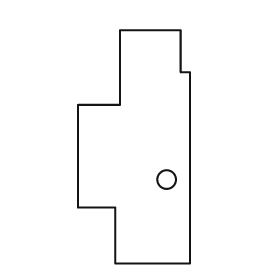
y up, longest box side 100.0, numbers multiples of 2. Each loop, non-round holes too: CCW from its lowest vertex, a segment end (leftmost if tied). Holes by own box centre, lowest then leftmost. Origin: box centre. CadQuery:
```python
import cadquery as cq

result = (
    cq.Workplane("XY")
    .moveTo(-8.0, -50.0)
    .lineTo(24.0, -50.0)
    .lineTo(24.0, 32.0)
    .lineTo(20.0, 32.0)
    .lineTo(20.0, 50.0)
    .lineTo(-6.0, 50.0)
    .lineTo(-6.0, 18.0)
    .lineTo(-24.0, 18.0)
    .lineTo(-24.0, -26.0)
    .lineTo(-8.0, -26.0)
    .close()
    .moveTo(14.0, -14.0)
    .circle(4.0)
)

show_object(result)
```